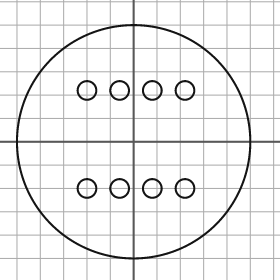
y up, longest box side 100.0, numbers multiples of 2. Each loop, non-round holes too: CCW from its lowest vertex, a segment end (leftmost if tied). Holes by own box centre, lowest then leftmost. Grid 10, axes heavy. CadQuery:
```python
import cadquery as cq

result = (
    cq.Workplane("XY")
    .moveTo(0.0, 0.0)
    .circle(50.0)
    .moveTo(-20.0, -20.0)
    .circle(4.0)
    .moveTo(-6.0, -20.0)
    .circle(4.0)
    .moveTo(8.0, -20.0)
    .circle(4.0)
    .moveTo(22.0, -20.0)
    .circle(4.0)
    .moveTo(-20.0, 22.0)
    .circle(4.0)
    .moveTo(-6.0, 22.0)
    .circle(4.0)
    .moveTo(8.0, 22.0)
    .circle(4.0)
    .moveTo(22.0, 22.0)
    .circle(4.0)
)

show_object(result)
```